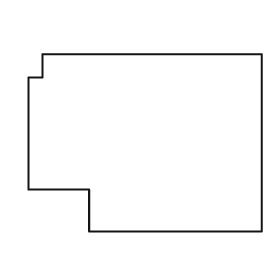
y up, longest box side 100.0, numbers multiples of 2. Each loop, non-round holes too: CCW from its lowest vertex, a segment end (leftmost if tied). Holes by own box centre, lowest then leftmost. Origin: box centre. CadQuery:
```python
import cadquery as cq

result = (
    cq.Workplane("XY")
    .moveTo(-24.0, -38.0)
    .lineTo(50.0, -38.0)
    .lineTo(50.0, 38.0)
    .lineTo(-44.0, 38.0)
    .lineTo(-44.0, 28.0)
    .lineTo(-50.0, 28.0)
    .lineTo(-50.0, -20.0)
    .lineTo(-24.0, -20.0)
    .close()
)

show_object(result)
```